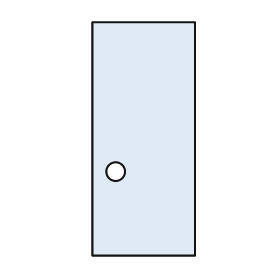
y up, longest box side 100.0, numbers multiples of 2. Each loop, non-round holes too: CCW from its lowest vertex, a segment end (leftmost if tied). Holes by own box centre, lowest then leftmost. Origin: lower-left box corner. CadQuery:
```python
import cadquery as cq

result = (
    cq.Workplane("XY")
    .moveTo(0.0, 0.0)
    .lineTo(44.0, 0.0)
    .lineTo(44.0, 100.0)
    .lineTo(0.0, 100.0)
    .close()
    .moveTo(10.0, 36.0)
    .circle(4.0)
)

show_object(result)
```